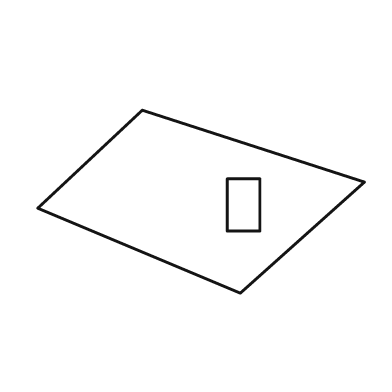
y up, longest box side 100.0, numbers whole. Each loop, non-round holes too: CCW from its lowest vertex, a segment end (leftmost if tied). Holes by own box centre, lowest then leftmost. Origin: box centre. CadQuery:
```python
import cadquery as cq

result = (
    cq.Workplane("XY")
    .moveTo(12.0, -28.0)
    .lineTo(50.0, 6.0)
    .lineTo(-18.0, 28.0)
    .lineTo(-50.0, -2.0)
    .close()
    .moveTo(8.0, -9.0)
    .lineTo(18.0, -9.0)
    .lineTo(18.0, 7.0)
    .lineTo(8.0, 7.0)
    .close()
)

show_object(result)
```